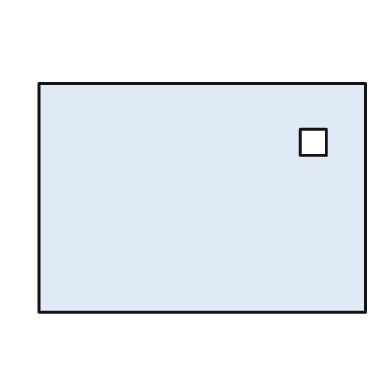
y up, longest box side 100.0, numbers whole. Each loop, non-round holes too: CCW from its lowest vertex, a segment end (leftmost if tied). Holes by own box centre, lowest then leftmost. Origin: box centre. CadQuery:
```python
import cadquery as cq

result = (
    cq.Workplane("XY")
    .moveTo(-50.0, -35.0)
    .lineTo(50.0, -35.0)
    .lineTo(50.0, 35.0)
    .lineTo(-50.0, 35.0)
    .close()
    .moveTo(30.0, 13.0)
    .lineTo(38.0, 13.0)
    .lineTo(38.0, 21.0)
    .lineTo(30.0, 21.0)
    .close()
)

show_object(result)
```